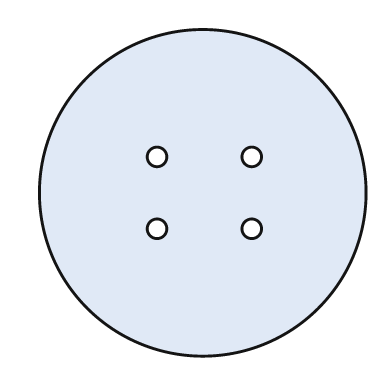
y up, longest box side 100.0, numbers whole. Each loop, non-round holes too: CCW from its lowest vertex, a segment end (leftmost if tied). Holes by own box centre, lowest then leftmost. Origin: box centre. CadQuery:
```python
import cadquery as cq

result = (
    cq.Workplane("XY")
    .moveTo(0.0, 0.0)
    .circle(50.0)
    .moveTo(-14.0, -11.0)
    .circle(3.0)
    .moveTo(15.0, -11.0)
    .circle(3.0)
    .moveTo(-14.0, 11.0)
    .circle(3.0)
    .moveTo(15.0, 11.0)
    .circle(3.0)
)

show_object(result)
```